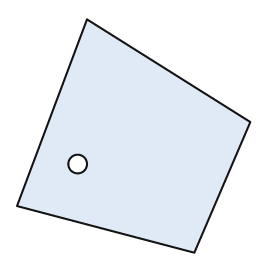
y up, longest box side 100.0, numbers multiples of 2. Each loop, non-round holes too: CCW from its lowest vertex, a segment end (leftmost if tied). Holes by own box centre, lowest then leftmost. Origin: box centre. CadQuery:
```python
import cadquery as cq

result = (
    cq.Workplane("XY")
    .moveTo(26.0, -50.0)
    .lineTo(50.0, 6.0)
    .lineTo(-20.0, 50.0)
    .lineTo(-50.0, -30.0)
    .close()
    .moveTo(-24.0, -12.0)
    .circle(4.0)
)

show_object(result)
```